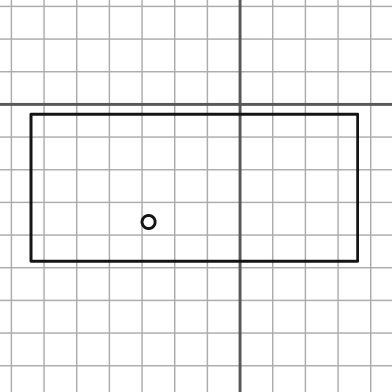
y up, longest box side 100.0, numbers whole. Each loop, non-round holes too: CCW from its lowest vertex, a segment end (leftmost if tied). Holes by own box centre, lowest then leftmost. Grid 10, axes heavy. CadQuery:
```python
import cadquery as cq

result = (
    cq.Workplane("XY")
    .moveTo(-64.0, -48.0)
    .lineTo(36.0, -48.0)
    .lineTo(36.0, -3.0)
    .lineTo(-64.0, -3.0)
    .close()
    .moveTo(-28.0, -36.0)
    .circle(2.0)
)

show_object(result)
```